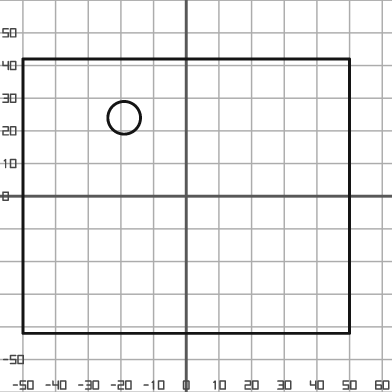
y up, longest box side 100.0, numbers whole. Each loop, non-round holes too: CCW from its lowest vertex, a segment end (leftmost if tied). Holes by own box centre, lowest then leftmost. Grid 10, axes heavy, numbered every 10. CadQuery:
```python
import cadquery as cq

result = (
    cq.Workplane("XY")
    .moveTo(-50.0, -42.0)
    .lineTo(50.0, -42.0)
    .lineTo(50.0, 42.0)
    .lineTo(-50.0, 42.0)
    .close()
    .moveTo(-19.0, 24.0)
    .circle(5.0)
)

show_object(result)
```